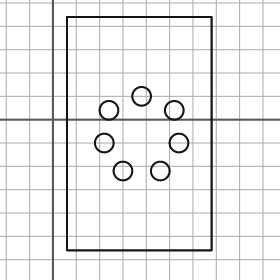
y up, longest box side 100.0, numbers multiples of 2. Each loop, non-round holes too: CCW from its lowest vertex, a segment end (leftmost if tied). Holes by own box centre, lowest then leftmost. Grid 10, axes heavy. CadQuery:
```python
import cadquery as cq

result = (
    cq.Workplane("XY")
    .moveTo(6.0, -56.0)
    .lineTo(68.0, -56.0)
    .lineTo(68.0, 44.0)
    .lineTo(6.0, 44.0)
    .close()
    .moveTo(30.0, -22.0)
    .circle(4.0)
    .moveTo(46.0, -22.0)
    .circle(4.0)
    .moveTo(22.0, -10.0)
    .circle(4.0)
    .moveTo(54.0, -10.0)
    .circle(4.0)
    .moveTo(24.0, 4.0)
    .circle(4.0)
    .moveTo(52.0, 4.0)
    .circle(4.0)
    .moveTo(38.0, 10.0)
    .circle(4.0)
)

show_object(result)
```